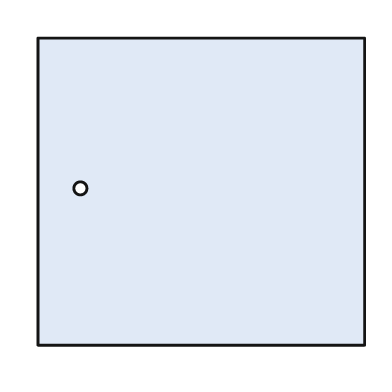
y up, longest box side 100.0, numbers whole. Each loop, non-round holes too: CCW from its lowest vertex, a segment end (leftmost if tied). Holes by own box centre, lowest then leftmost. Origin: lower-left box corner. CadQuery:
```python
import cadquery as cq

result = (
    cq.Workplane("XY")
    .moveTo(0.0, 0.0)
    .lineTo(100.0, 0.0)
    .lineTo(100.0, 94.0)
    .lineTo(0.0, 94.0)
    .close()
    .moveTo(13.0, 48.0)
    .circle(2.0)
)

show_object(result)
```